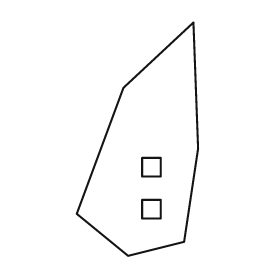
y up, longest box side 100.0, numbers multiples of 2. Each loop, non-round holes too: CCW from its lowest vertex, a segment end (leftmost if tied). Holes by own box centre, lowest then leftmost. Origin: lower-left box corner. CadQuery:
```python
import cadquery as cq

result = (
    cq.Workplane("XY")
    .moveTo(22.0, 0.0)
    .lineTo(46.0, 6.0)
    .lineTo(52.0, 46.0)
    .lineTo(50.0, 100.0)
    .lineTo(20.0, 72.0)
    .lineTo(0.0, 18.0)
    .close()
    .moveTo(28.0, 16.0)
    .lineTo(36.0, 16.0)
    .lineTo(36.0, 24.0)
    .lineTo(28.0, 24.0)
    .close()
    .moveTo(28.0, 34.0)
    .lineTo(36.0, 34.0)
    .lineTo(36.0, 42.0)
    .lineTo(28.0, 42.0)
    .close()
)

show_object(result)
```